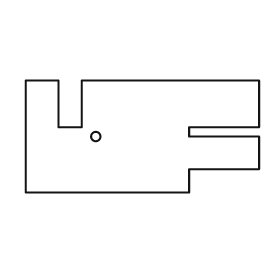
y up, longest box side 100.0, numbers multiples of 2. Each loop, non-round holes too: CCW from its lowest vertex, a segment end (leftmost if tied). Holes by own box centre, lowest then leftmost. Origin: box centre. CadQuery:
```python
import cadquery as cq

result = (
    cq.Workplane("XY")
    .moveTo(-50.0, -24.0)
    .lineTo(20.0, -24.0)
    .lineTo(20.0, -14.0)
    .lineTo(50.0, -14.0)
    .lineTo(50.0, 0.0)
    .lineTo(20.0, 0.0)
    .lineTo(20.0, 4.0)
    .lineTo(50.0, 4.0)
    .lineTo(50.0, 24.0)
    .lineTo(-26.0, 24.0)
    .lineTo(-26.0, 4.0)
    .lineTo(-36.0, 4.0)
    .lineTo(-36.0, 24.0)
    .lineTo(-50.0, 24.0)
    .close()
    .moveTo(-20.0, 0.0)
    .circle(2.0)
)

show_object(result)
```